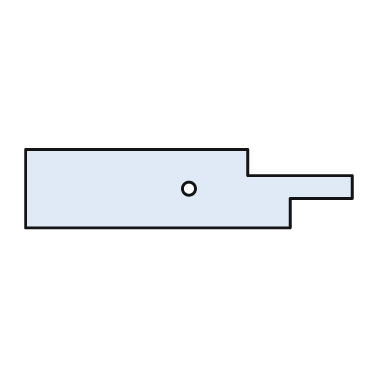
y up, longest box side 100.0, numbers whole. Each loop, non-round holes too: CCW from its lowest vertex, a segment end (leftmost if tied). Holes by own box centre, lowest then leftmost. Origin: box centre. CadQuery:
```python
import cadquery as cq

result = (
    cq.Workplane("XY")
    .moveTo(-50.0, -12.0)
    .lineTo(31.0, -12.0)
    .lineTo(31.0, -3.0)
    .lineTo(50.0, -3.0)
    .lineTo(50.0, 4.0)
    .lineTo(18.0, 4.0)
    .lineTo(18.0, 12.0)
    .lineTo(-50.0, 12.0)
    .close()
    .moveTo(0.0, 0.0)
    .circle(2.0)
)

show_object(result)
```